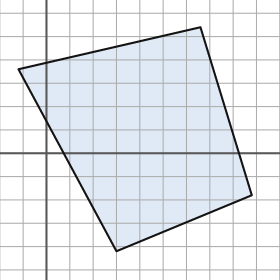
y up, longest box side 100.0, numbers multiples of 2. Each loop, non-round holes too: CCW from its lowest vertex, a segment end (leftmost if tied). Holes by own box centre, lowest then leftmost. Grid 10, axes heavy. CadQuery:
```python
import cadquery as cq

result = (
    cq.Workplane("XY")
    .moveTo(30.0, -42.0)
    .lineTo(88.0, -18.0)
    .lineTo(66.0, 54.0)
    .lineTo(-12.0, 36.0)
    .close()
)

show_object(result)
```